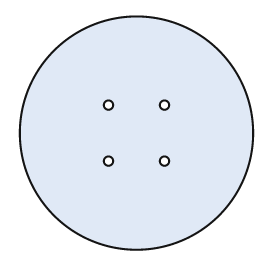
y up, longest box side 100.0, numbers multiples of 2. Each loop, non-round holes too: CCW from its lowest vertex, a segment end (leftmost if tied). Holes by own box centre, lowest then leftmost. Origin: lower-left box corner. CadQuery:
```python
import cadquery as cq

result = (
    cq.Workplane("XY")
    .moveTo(50.0, 50.0)
    .circle(50.0)
    .moveTo(38.0, 38.0)
    .circle(2.0)
    .moveTo(62.0, 38.0)
    .circle(2.0)
    .moveTo(38.0, 62.0)
    .circle(2.0)
    .moveTo(62.0, 62.0)
    .circle(2.0)
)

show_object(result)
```